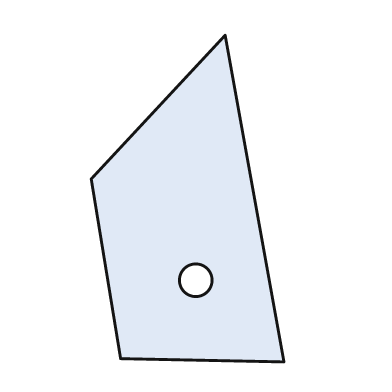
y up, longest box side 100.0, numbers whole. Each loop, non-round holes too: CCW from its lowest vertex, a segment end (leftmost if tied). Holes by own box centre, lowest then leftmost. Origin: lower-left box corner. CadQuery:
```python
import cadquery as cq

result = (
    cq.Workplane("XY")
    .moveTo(59.0, 0.0)
    .lineTo(41.0, 100.0)
    .lineTo(0.0, 56.0)
    .lineTo(9.0, 1.0)
    .close()
    .moveTo(32.0, 25.0)
    .circle(5.0)
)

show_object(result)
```